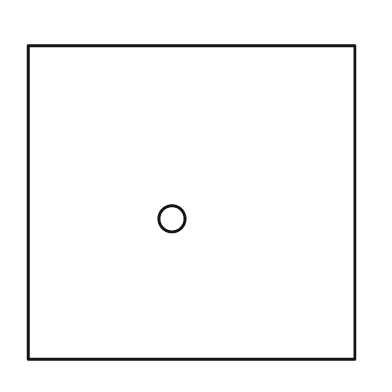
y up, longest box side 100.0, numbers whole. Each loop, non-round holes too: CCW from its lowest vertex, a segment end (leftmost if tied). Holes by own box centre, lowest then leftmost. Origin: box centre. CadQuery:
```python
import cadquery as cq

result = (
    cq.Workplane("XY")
    .moveTo(-50.0, -48.0)
    .lineTo(50.0, -48.0)
    .lineTo(50.0, 48.0)
    .lineTo(-50.0, 48.0)
    .close()
    .moveTo(-6.0, -5.0)
    .circle(4.0)
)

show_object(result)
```